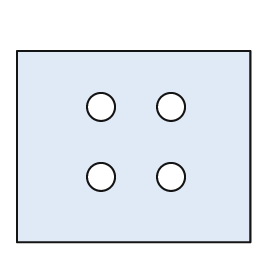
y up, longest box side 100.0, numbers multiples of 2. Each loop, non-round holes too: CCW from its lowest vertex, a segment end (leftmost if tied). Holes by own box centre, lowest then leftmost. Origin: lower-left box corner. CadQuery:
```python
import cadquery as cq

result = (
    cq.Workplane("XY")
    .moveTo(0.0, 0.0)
    .lineTo(100.0, 0.0)
    .lineTo(100.0, 82.0)
    .lineTo(0.0, 82.0)
    .close()
    .moveTo(36.0, 28.0)
    .circle(6.0)
    .moveTo(66.0, 28.0)
    .circle(6.0)
    .moveTo(36.0, 58.0)
    .circle(6.0)
    .moveTo(66.0, 58.0)
    .circle(6.0)
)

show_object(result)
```